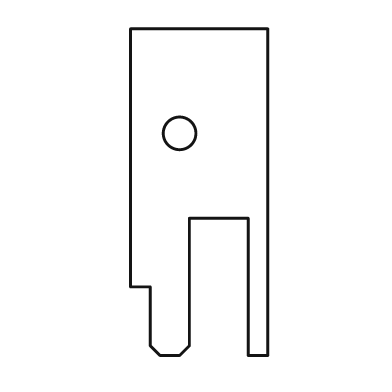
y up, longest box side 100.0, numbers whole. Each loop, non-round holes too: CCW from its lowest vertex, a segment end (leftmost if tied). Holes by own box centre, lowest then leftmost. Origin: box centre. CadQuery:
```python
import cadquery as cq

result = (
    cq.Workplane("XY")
    .moveTo(-12.0, -50.0)
    .lineTo(-6.0, -50.0)
    .lineTo(-3.0, -47.0)
    .lineTo(-3.0, -8.0)
    .lineTo(15.0, -8.0)
    .lineTo(15.0, -50.0)
    .lineTo(21.0, -50.0)
    .lineTo(21.0, 50.0)
    .lineTo(-21.0, 50.0)
    .lineTo(-21.0, -29.0)
    .lineTo(-15.0, -29.0)
    .lineTo(-15.0, -47.0)
    .close()
    .moveTo(-6.0, 18.0)
    .circle(5.0)
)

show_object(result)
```